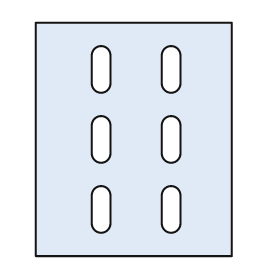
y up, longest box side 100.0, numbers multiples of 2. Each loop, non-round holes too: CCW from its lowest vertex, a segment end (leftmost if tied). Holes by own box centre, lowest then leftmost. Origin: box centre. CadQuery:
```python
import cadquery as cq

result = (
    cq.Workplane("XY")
    .moveTo(-42.0, -50.0)
    .lineTo(42.0, -50.0)
    .lineTo(42.0, 50.0)
    .lineTo(-42.0, 50.0)
    .close()
    .moveTo(-18.0, -36.0)
    .threePointArc((-14.0, -40.0), (-10.0, -36.0))
    .lineTo(-10.0, -24.0)
    .threePointArc((-14.0, -20.0), (-18.0, -24.0))
    .close()
    .moveTo(12.0, -36.0)
    .threePointArc((16.0, -40.0), (20.0, -36.0))
    .lineTo(20.0, -24.0)
    .threePointArc((16.0, -20.0), (12.0, -24.0))
    .close()
    .moveTo(-18.0, -6.0)
    .threePointArc((-14.0, -10.0), (-10.0, -6.0))
    .lineTo(-10.0, 6.0)
    .threePointArc((-14.0, 10.0), (-18.0, 6.0))
    .close()
    .moveTo(12.0, -6.0)
    .threePointArc((16.0, -10.0), (20.0, -6.0))
    .lineTo(20.0, 6.0)
    .threePointArc((16.0, 10.0), (12.0, 6.0))
    .close()
    .moveTo(-18.0, 24.0)
    .threePointArc((-14.0, 20.0), (-10.0, 24.0))
    .lineTo(-10.0, 36.0)
    .threePointArc((-14.0, 40.0), (-18.0, 36.0))
    .close()
    .moveTo(12.0, 24.0)
    .threePointArc((16.0, 20.0), (20.0, 24.0))
    .lineTo(20.0, 36.0)
    .threePointArc((16.0, 40.0), (12.0, 36.0))
    .close()
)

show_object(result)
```